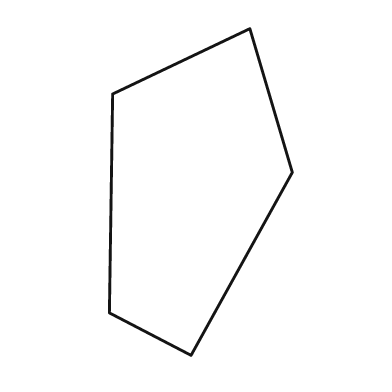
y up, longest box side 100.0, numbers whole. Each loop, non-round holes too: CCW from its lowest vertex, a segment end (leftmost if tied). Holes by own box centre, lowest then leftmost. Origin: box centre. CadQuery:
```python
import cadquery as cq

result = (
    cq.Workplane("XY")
    .moveTo(-3.0, -50.0)
    .lineTo(28.0, 6.0)
    .lineTo(15.0, 50.0)
    .lineTo(-27.0, 30.0)
    .lineTo(-28.0, -37.0)
    .close()
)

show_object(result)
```